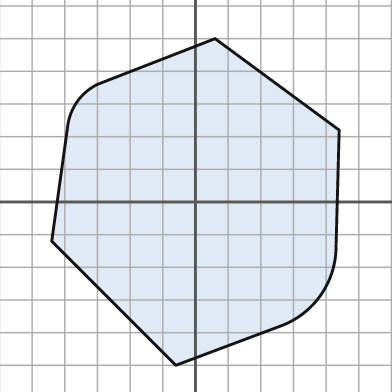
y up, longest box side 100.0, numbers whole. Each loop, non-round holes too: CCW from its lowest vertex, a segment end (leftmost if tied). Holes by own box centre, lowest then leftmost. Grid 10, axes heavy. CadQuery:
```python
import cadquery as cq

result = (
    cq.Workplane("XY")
    .moveTo(-6.0, -50.0)
    .lineTo(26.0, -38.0)
    .threePointArc((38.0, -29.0), (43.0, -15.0))
    .lineTo(44.0, 22.0)
    .lineTo(6.0, 50.0)
    .lineTo(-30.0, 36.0)
    .threePointArc((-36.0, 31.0), (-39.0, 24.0))
    .lineTo(-44.0, -12.0)
    .close()
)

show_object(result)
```